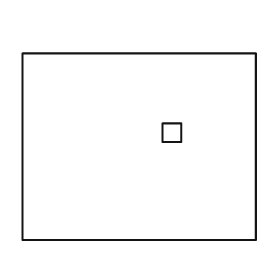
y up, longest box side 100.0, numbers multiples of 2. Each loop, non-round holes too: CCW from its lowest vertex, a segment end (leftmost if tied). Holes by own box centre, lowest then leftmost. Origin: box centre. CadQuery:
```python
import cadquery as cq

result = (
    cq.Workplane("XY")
    .moveTo(-50.0, -40.0)
    .lineTo(50.0, -40.0)
    .lineTo(50.0, 40.0)
    .lineTo(-50.0, 40.0)
    .close()
    .moveTo(10.0, 2.0)
    .lineTo(18.0, 2.0)
    .lineTo(18.0, 10.0)
    .lineTo(10.0, 10.0)
    .close()
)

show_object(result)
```